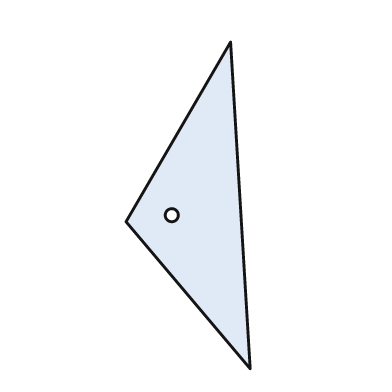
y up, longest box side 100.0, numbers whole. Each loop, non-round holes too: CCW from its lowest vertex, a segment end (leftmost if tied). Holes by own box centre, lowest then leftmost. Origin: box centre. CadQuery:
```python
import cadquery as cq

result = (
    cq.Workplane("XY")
    .moveTo(19.0, -50.0)
    .lineTo(13.0, 50.0)
    .lineTo(-19.0, -5.0)
    .close()
    .moveTo(-5.0, -3.0)
    .circle(2.0)
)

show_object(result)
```